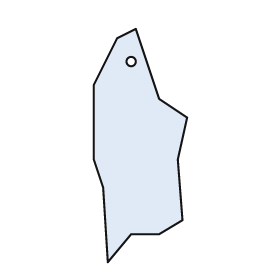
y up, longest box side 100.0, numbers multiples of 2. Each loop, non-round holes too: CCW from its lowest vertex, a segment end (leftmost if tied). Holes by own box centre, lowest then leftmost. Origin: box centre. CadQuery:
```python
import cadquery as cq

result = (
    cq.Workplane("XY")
    .moveTo(-14.0, -50.0)
    .lineTo(-4.0, -38.0)
    .lineTo(8.0, -38.0)
    .lineTo(18.0, -32.0)
    .lineTo(16.0, -6.0)
    .lineTo(20.0, 12.0)
    .lineTo(8.0, 20.0)
    .lineTo(-2.0, 50.0)
    .lineTo(-10.0, 46.0)
    .lineTo(-20.0, 26.0)
    .lineTo(-20.0, -6.0)
    .lineTo(-16.0, -18.0)
    .close()
    .moveTo(-4.0, 36.0)
    .circle(2.0)
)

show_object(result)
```